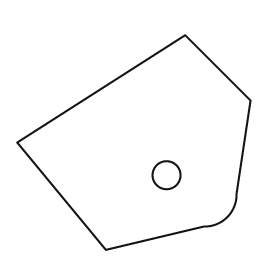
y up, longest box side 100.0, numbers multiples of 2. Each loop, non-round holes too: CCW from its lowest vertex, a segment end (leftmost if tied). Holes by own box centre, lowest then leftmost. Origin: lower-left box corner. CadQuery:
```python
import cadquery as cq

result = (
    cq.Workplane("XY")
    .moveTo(38.0, 0.0)
    .lineTo(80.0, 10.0)
    .threePointArc((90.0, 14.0), (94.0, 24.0))
    .lineTo(100.0, 64.0)
    .lineTo(72.0, 92.0)
    .lineTo(0.0, 46.0)
    .close()
    .moveTo(64.0, 32.0)
    .circle(6.0)
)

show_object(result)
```